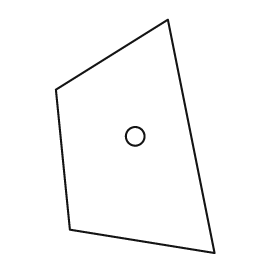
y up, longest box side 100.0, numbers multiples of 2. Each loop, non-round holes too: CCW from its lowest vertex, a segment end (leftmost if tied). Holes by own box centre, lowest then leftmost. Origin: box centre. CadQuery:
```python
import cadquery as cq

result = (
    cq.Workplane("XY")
    .moveTo(34.0, -50.0)
    .lineTo(14.0, 50.0)
    .lineTo(-34.0, 20.0)
    .lineTo(-28.0, -40.0)
    .close()
    .moveTo(0.0, 0.0)
    .circle(4.0)
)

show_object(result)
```